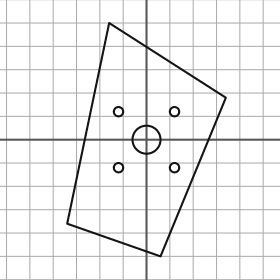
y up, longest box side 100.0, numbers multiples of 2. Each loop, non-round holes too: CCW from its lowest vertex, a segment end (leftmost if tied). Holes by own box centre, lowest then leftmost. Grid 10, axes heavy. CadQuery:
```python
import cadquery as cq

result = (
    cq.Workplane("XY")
    .moveTo(6.0, -50.0)
    .lineTo(34.0, 18.0)
    .lineTo(-16.0, 50.0)
    .lineTo(-34.0, -36.0)
    .close()
    .moveTo(-12.0, -12.0)
    .circle(2.0)
    .moveTo(12.0, -12.0)
    .circle(2.0)
    .moveTo(0.0, 0.0)
    .circle(6.0)
    .moveTo(-12.0, 12.0)
    .circle(2.0)
    .moveTo(12.0, 12.0)
    .circle(2.0)
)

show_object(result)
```